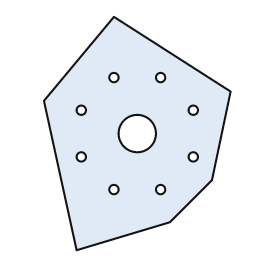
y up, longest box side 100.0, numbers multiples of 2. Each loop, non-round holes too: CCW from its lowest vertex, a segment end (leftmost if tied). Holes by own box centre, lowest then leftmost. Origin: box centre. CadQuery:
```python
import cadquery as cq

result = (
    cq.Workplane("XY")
    .moveTo(-26.0, -50.0)
    .lineTo(14.0, -38.0)
    .lineTo(32.0, -20.0)
    .lineTo(40.0, 18.0)
    .lineTo(-10.0, 50.0)
    .lineTo(-40.0, 14.0)
    .close()
    .moveTo(-10.0, -24.0)
    .circle(2.0)
    .moveTo(10.0, -24.0)
    .circle(2.0)
    .moveTo(-24.0, -10.0)
    .circle(2.0)
    .moveTo(24.0, -10.0)
    .circle(2.0)
    .moveTo(0.0, 0.0)
    .circle(8.0)
    .moveTo(-24.0, 10.0)
    .circle(2.0)
    .moveTo(24.0, 10.0)
    .circle(2.0)
    .moveTo(-10.0, 24.0)
    .circle(2.0)
    .moveTo(10.0, 24.0)
    .circle(2.0)
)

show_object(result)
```